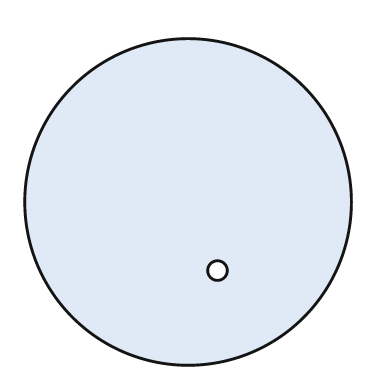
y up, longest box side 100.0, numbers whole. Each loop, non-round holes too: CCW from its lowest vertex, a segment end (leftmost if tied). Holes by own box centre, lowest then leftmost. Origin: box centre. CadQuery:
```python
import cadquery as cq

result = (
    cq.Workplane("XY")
    .moveTo(0.0, 0.0)
    .circle(50.0)
    .moveTo(9.0, -21.0)
    .circle(3.0)
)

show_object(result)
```